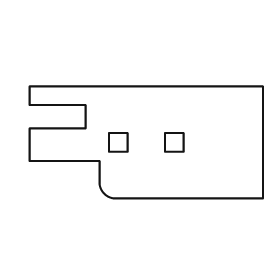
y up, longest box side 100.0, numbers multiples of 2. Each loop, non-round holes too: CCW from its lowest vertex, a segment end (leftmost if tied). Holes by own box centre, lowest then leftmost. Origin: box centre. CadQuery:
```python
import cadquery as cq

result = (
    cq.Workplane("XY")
    .moveTo(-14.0, -24.0)
    .lineTo(50.0, -24.0)
    .lineTo(50.0, 24.0)
    .lineTo(-50.0, 24.0)
    .lineTo(-50.0, 16.0)
    .lineTo(-26.0, 16.0)
    .lineTo(-26.0, 6.0)
    .lineTo(-50.0, 6.0)
    .lineTo(-50.0, -8.0)
    .lineTo(-20.0, -8.0)
    .lineTo(-20.0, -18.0)
    .threePointArc((-18.0, -22.0), (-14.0, -24.0))
    .close()
    .moveTo(-16.0, -4.0)
    .lineTo(-8.0, -4.0)
    .lineTo(-8.0, 4.0)
    .lineTo(-16.0, 4.0)
    .close()
    .moveTo(8.0, -4.0)
    .lineTo(16.0, -4.0)
    .lineTo(16.0, 4.0)
    .lineTo(8.0, 4.0)
    .close()
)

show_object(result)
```